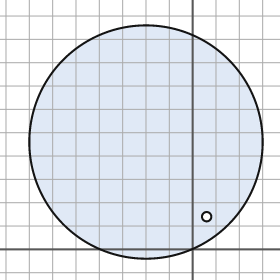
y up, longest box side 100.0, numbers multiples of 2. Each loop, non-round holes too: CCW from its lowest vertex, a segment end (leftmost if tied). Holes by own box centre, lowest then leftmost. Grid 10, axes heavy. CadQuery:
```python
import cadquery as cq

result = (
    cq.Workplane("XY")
    .moveTo(-20.0, 46.0)
    .circle(50.0)
    .moveTo(6.0, 14.0)
    .circle(2.0)
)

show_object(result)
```